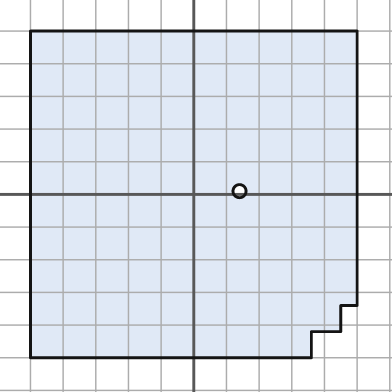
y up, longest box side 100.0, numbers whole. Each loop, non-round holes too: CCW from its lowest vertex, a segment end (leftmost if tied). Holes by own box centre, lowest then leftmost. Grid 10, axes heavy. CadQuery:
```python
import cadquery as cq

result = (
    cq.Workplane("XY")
    .moveTo(-50.0, -50.0)
    .lineTo(36.0, -50.0)
    .lineTo(36.0, -42.0)
    .lineTo(45.0, -42.0)
    .lineTo(45.0, -34.0)
    .lineTo(50.0, -34.0)
    .lineTo(50.0, 50.0)
    .lineTo(-50.0, 50.0)
    .close()
    .moveTo(14.0, 1.0)
    .circle(2.0)
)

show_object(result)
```